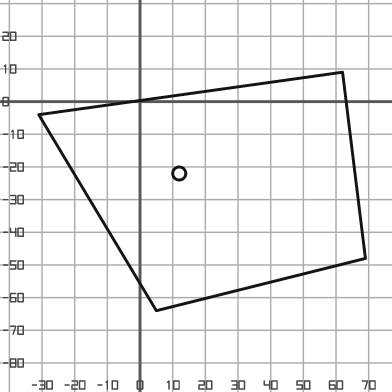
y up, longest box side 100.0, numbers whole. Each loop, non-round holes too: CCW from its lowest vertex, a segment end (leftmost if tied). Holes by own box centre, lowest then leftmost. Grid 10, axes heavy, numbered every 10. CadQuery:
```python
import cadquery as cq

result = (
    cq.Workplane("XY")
    .moveTo(5.0, -64.0)
    .lineTo(69.0, -48.0)
    .lineTo(62.0, 9.0)
    .lineTo(-31.0, -4.0)
    .close()
    .moveTo(12.0, -22.0)
    .circle(2.0)
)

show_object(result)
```